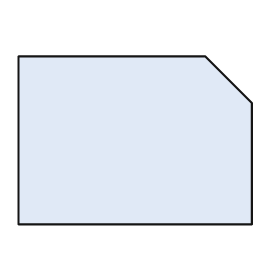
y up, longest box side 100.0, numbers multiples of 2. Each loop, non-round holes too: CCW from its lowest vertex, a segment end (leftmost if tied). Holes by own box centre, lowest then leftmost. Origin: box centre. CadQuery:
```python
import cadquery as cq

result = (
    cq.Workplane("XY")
    .moveTo(-50.0, -36.0)
    .lineTo(50.0, -36.0)
    .lineTo(50.0, 16.0)
    .lineTo(30.0, 36.0)
    .lineTo(-50.0, 36.0)
    .close()
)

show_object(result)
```